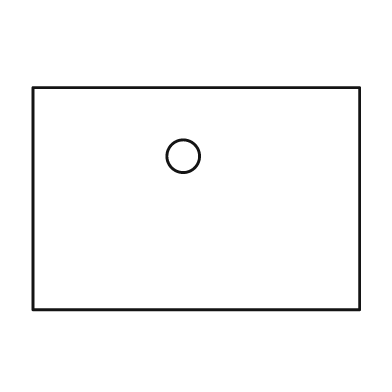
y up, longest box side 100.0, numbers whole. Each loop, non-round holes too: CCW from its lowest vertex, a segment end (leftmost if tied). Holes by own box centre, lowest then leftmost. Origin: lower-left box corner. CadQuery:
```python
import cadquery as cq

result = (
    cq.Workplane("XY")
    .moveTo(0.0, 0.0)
    .lineTo(100.0, 0.0)
    .lineTo(100.0, 68.0)
    .lineTo(0.0, 68.0)
    .close()
    .moveTo(46.0, 47.0)
    .circle(5.0)
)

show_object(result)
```